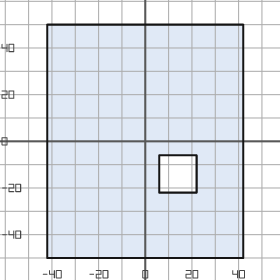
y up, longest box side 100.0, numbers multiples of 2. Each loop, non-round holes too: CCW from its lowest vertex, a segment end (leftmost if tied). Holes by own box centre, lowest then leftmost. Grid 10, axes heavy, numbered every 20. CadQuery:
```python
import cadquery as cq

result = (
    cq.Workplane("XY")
    .moveTo(-42.0, -50.0)
    .lineTo(42.0, -50.0)
    .lineTo(42.0, 50.0)
    .lineTo(-42.0, 50.0)
    .close()
    .moveTo(6.0, -22.0)
    .lineTo(22.0, -22.0)
    .lineTo(22.0, -6.0)
    .lineTo(6.0, -6.0)
    .close()
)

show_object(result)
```